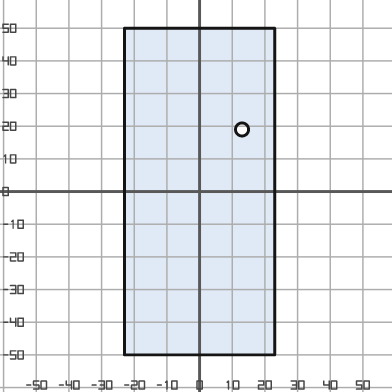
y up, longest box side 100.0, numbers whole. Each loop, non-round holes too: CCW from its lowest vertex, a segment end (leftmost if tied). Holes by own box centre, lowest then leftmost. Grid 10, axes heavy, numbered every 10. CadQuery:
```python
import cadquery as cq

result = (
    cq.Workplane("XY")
    .moveTo(-23.0, -50.0)
    .lineTo(23.0, -50.0)
    .lineTo(23.0, 50.0)
    .lineTo(-23.0, 50.0)
    .close()
    .moveTo(13.0, 19.0)
    .circle(2.0)
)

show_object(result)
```